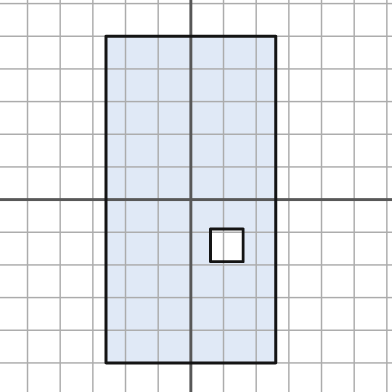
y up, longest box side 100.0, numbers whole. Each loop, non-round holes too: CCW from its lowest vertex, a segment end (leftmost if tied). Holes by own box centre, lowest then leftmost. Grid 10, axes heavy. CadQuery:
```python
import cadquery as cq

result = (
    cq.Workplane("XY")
    .moveTo(-26.0, -50.0)
    .lineTo(26.0, -50.0)
    .lineTo(26.0, 50.0)
    .lineTo(-26.0, 50.0)
    .close()
    .moveTo(6.0, -19.0)
    .lineTo(16.0, -19.0)
    .lineTo(16.0, -9.0)
    .lineTo(6.0, -9.0)
    .close()
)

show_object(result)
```